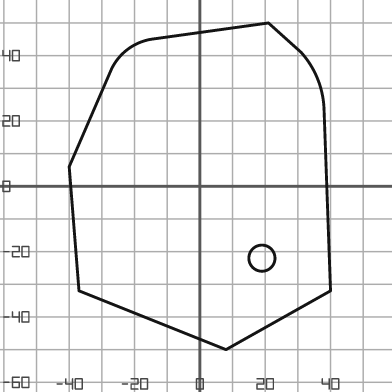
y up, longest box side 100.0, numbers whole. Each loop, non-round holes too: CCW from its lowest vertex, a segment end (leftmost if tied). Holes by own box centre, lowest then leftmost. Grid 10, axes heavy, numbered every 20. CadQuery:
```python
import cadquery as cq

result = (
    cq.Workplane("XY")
    .moveTo(8.0, -50.0)
    .lineTo(40.0, -32.0)
    .lineTo(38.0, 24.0)
    .threePointArc((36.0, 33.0), (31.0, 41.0))
    .lineTo(21.0, 50.0)
    .lineTo(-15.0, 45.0)
    .threePointArc((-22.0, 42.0), (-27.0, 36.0))
    .lineTo(-40.0, 6.0)
    .lineTo(-37.0, -32.0)
    .close()
    .moveTo(19.0, -22.0)
    .circle(4.0)
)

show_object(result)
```